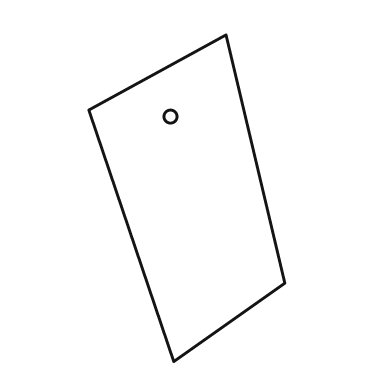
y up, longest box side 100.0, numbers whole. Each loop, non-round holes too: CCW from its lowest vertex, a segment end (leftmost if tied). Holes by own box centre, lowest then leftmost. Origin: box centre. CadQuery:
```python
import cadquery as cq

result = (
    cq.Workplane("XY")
    .moveTo(-4.0, -50.0)
    .lineTo(30.0, -26.0)
    .lineTo(12.0, 50.0)
    .lineTo(-30.0, 27.0)
    .close()
    .moveTo(-5.0, 25.0)
    .circle(2.0)
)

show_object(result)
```